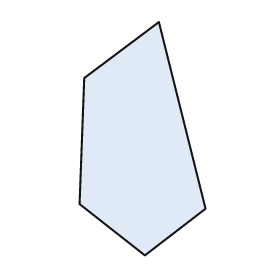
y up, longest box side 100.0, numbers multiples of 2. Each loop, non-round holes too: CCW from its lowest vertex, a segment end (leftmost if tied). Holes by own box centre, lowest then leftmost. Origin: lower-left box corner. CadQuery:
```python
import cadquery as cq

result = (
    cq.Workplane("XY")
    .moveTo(28.0, 0.0)
    .lineTo(54.0, 20.0)
    .lineTo(34.0, 100.0)
    .lineTo(2.0, 76.0)
    .lineTo(0.0, 22.0)
    .close()
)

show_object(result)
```